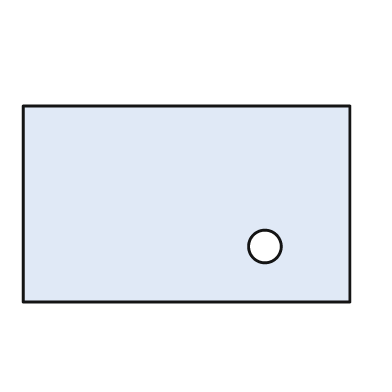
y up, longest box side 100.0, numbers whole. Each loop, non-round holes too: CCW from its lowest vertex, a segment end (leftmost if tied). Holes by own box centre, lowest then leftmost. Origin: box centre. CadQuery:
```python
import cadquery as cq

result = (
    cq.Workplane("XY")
    .moveTo(-50.0, -30.0)
    .lineTo(50.0, -30.0)
    .lineTo(50.0, 30.0)
    .lineTo(-50.0, 30.0)
    .close()
    .moveTo(24.0, -13.0)
    .circle(5.0)
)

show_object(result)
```